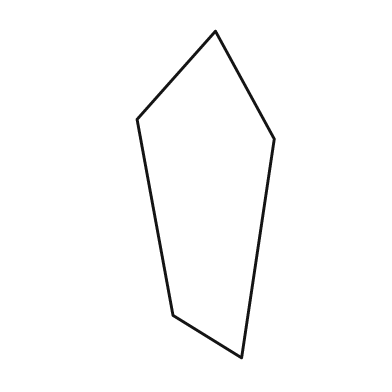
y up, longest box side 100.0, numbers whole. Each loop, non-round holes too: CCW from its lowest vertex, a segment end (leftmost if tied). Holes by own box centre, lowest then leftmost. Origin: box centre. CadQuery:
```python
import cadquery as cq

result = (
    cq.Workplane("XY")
    .moveTo(11.0, -50.0)
    .lineTo(21.0, 17.0)
    .lineTo(3.0, 50.0)
    .lineTo(-21.0, 23.0)
    .lineTo(-10.0, -37.0)
    .close()
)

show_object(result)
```